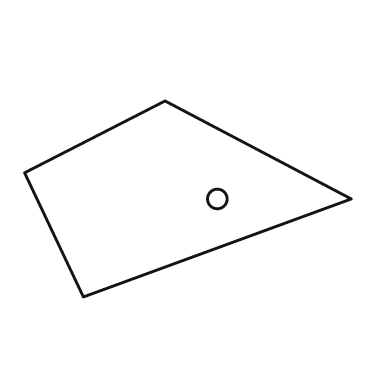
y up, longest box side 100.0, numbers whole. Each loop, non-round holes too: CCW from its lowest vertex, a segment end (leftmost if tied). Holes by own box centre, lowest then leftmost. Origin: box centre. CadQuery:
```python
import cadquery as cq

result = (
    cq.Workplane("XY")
    .moveTo(-32.0, -30.0)
    .lineTo(50.0, 0.0)
    .lineTo(-7.0, 30.0)
    .lineTo(-50.0, 8.0)
    .close()
    .moveTo(9.0, 0.0)
    .circle(3.0)
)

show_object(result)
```